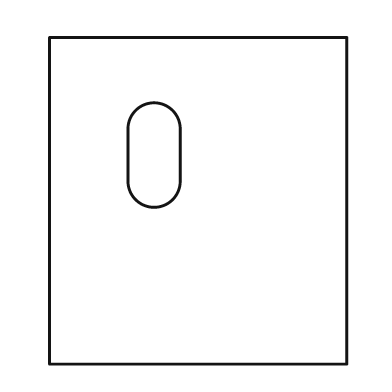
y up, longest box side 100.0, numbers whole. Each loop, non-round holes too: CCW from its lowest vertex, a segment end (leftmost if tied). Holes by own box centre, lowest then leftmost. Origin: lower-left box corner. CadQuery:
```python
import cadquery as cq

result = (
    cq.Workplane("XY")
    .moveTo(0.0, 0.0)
    .lineTo(91.0, 0.0)
    .lineTo(91.0, 100.0)
    .lineTo(0.0, 100.0)
    .close()
    .moveTo(24.0, 56.0)
    .threePointArc((32.0, 48.0), (40.0, 56.0))
    .lineTo(40.0, 72.0)
    .threePointArc((32.0, 80.0), (24.0, 72.0))
    .close()
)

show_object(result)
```